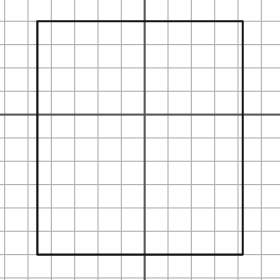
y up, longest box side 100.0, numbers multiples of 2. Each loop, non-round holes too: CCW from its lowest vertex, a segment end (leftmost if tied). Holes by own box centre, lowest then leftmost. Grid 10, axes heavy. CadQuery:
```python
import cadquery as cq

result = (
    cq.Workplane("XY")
    .moveTo(-46.0, -60.0)
    .lineTo(42.0, -60.0)
    .lineTo(42.0, 40.0)
    .lineTo(-46.0, 40.0)
    .close()
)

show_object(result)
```